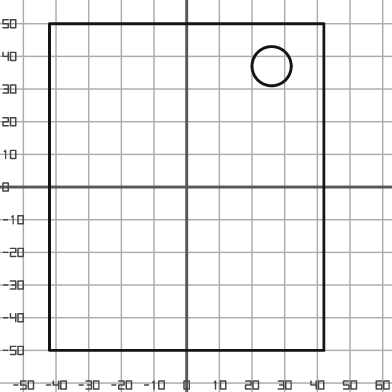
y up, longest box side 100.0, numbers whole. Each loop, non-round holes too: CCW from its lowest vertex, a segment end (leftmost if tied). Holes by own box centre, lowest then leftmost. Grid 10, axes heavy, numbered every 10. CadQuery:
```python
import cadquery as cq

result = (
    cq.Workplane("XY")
    .moveTo(-42.0, -50.0)
    .lineTo(42.0, -50.0)
    .lineTo(42.0, 50.0)
    .lineTo(-42.0, 50.0)
    .close()
    .moveTo(26.0, 37.0)
    .circle(6.0)
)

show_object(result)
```